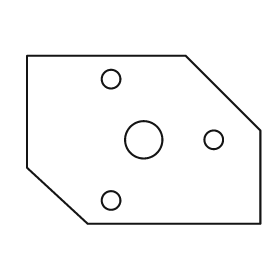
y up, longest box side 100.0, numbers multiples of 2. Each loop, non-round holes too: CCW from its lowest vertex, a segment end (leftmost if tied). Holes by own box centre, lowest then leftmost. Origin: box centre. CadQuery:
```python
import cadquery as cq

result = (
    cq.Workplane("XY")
    .moveTo(-24.0, -36.0)
    .lineTo(50.0, -36.0)
    .lineTo(50.0, 4.0)
    .lineTo(18.0, 36.0)
    .lineTo(-50.0, 36.0)
    .lineTo(-50.0, -12.0)
    .close()
    .moveTo(-14.0, -26.0)
    .circle(4.0)
    .moveTo(0.0, 0.0)
    .circle(8.0)
    .moveTo(30.0, 0.0)
    .circle(4.0)
    .moveTo(-14.0, 26.0)
    .circle(4.0)
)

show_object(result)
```